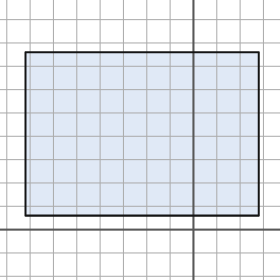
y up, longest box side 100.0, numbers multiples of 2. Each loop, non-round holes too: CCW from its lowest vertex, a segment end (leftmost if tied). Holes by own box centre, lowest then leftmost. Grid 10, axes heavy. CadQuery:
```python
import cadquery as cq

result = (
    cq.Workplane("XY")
    .moveTo(-72.0, 6.0)
    .lineTo(28.0, 6.0)
    .lineTo(28.0, 76.0)
    .lineTo(-72.0, 76.0)
    .close()
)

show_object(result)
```